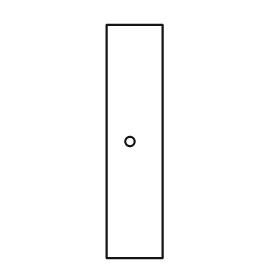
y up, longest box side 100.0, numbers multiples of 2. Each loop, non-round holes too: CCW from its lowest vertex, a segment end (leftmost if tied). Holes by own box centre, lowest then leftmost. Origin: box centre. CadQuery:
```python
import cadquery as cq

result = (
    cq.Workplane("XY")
    .moveTo(-12.0, -50.0)
    .lineTo(12.0, -50.0)
    .lineTo(12.0, 50.0)
    .lineTo(-12.0, 50.0)
    .close()
    .moveTo(-2.0, 0.0)
    .circle(2.0)
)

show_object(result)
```